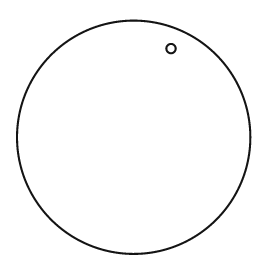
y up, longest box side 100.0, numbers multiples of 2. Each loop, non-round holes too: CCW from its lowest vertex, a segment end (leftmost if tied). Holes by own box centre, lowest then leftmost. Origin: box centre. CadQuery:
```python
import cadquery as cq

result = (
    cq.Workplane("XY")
    .moveTo(0.0, 0.0)
    .circle(50.0)
    .moveTo(16.0, 38.0)
    .circle(2.0)
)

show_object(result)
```